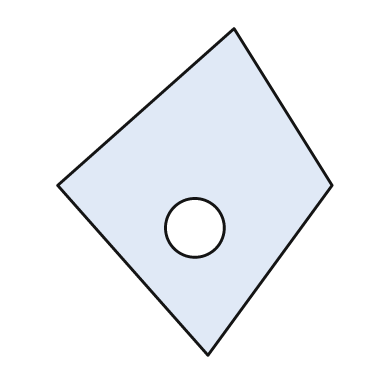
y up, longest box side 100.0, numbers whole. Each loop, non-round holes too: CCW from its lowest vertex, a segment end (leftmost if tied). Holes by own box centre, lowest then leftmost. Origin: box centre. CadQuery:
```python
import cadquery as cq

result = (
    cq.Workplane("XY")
    .moveTo(4.0, -50.0)
    .lineTo(42.0, 2.0)
    .lineTo(12.0, 50.0)
    .lineTo(-42.0, 2.0)
    .close()
    .moveTo(0.0, -11.0)
    .circle(9.0)
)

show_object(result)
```